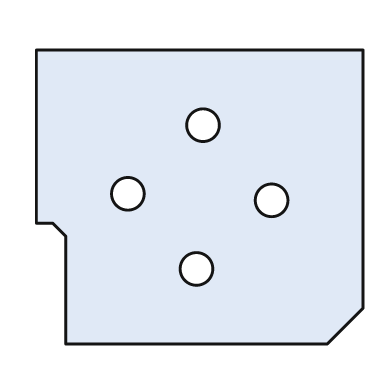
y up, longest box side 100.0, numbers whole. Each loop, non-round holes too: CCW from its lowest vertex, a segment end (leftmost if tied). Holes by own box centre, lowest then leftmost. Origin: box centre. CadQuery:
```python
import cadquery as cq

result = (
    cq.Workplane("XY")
    .moveTo(-41.0, -45.0)
    .lineTo(39.0, -45.0)
    .lineTo(50.0, -34.0)
    .lineTo(50.0, 45.0)
    .lineTo(-50.0, 45.0)
    .lineTo(-50.0, -8.0)
    .lineTo(-45.0, -8.0)
    .lineTo(-41.0, -12.0)
    .close()
    .moveTo(-1.0, -22.0)
    .circle(5.0)
    .moveTo(22.0, -1.0)
    .circle(5.0)
    .moveTo(-22.0, 1.0)
    .circle(5.0)
    .moveTo(1.0, 22.0)
    .circle(5.0)
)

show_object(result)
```